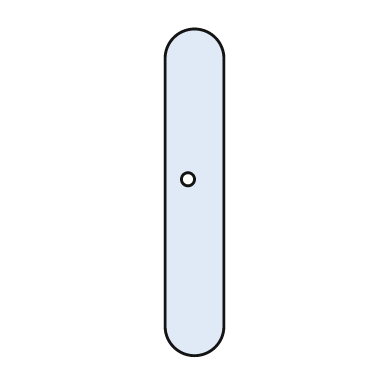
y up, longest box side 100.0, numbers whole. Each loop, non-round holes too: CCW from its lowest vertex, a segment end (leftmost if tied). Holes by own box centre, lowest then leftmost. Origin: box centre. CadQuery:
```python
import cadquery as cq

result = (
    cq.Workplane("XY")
    .moveTo(-9.0, -41.0)
    .threePointArc((0.0, -50.0), (9.0, -41.0))
    .lineTo(9.0, 41.0)
    .threePointArc((0.0, 50.0), (-9.0, 41.0))
    .close()
    .moveTo(-2.0, 4.0)
    .circle(2.0)
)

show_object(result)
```